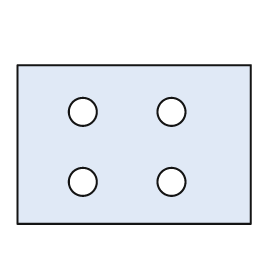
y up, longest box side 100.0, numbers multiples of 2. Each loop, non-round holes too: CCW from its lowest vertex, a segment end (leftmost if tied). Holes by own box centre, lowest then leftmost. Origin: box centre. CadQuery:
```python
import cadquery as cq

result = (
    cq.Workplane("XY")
    .moveTo(-50.0, -34.0)
    .lineTo(50.0, -34.0)
    .lineTo(50.0, 34.0)
    .lineTo(-50.0, 34.0)
    .close()
    .moveTo(-22.0, -16.0)
    .circle(6.0)
    .moveTo(16.0, -16.0)
    .circle(6.0)
    .moveTo(-22.0, 14.0)
    .circle(6.0)
    .moveTo(16.0, 14.0)
    .circle(6.0)
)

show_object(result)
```